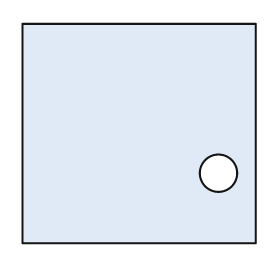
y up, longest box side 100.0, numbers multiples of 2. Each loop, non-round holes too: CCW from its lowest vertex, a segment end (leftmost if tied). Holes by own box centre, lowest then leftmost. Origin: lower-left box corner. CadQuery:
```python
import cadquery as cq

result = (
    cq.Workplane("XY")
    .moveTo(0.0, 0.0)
    .lineTo(100.0, 0.0)
    .lineTo(100.0, 94.0)
    .lineTo(0.0, 94.0)
    .close()
    .moveTo(84.0, 30.0)
    .circle(8.0)
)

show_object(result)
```